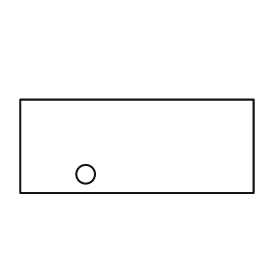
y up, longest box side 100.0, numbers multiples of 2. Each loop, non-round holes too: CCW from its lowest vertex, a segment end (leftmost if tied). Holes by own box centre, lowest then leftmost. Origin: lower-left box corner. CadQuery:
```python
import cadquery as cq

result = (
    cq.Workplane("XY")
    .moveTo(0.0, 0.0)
    .lineTo(100.0, 0.0)
    .lineTo(100.0, 40.0)
    .lineTo(0.0, 40.0)
    .close()
    .moveTo(28.0, 8.0)
    .circle(4.0)
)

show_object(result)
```